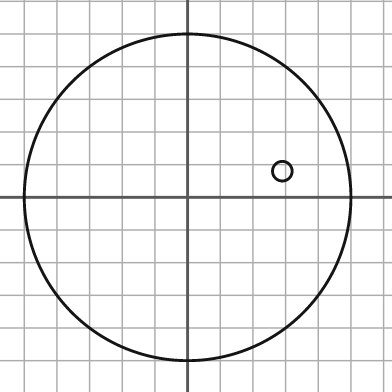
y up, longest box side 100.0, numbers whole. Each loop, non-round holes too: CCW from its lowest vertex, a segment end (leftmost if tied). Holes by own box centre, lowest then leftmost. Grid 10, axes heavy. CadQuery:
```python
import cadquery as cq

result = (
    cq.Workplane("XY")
    .moveTo(0.0, 0.0)
    .circle(50.0)
    .moveTo(29.0, 8.0)
    .circle(3.0)
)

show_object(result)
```